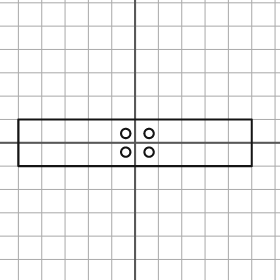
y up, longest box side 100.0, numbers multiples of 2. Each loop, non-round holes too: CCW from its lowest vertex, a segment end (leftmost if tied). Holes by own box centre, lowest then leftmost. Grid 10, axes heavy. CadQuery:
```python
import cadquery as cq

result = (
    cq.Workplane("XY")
    .moveTo(-50.0, -10.0)
    .lineTo(50.0, -10.0)
    .lineTo(50.0, 10.0)
    .lineTo(-50.0, 10.0)
    .close()
    .moveTo(-4.0, -4.0)
    .circle(2.0)
    .moveTo(6.0, -4.0)
    .circle(2.0)
    .moveTo(-4.0, 4.0)
    .circle(2.0)
    .moveTo(6.0, 4.0)
    .circle(2.0)
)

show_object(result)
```